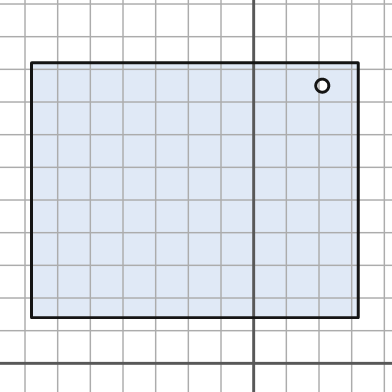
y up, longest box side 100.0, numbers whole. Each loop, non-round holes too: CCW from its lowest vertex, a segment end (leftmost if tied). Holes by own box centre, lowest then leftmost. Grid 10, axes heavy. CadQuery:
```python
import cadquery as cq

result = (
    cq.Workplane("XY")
    .moveTo(-68.0, 14.0)
    .lineTo(32.0, 14.0)
    .lineTo(32.0, 92.0)
    .lineTo(-68.0, 92.0)
    .close()
    .moveTo(21.0, 85.0)
    .circle(2.0)
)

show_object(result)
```